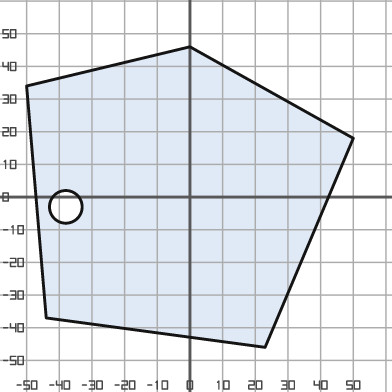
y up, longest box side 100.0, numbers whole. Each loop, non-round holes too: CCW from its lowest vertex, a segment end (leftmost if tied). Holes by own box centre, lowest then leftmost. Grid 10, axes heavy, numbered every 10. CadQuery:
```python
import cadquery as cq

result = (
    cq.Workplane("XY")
    .moveTo(23.0, -46.0)
    .lineTo(50.0, 18.0)
    .lineTo(0.0, 46.0)
    .lineTo(-50.0, 34.0)
    .lineTo(-44.0, -37.0)
    .close()
    .moveTo(-38.0, -3.0)
    .circle(5.0)
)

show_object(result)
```